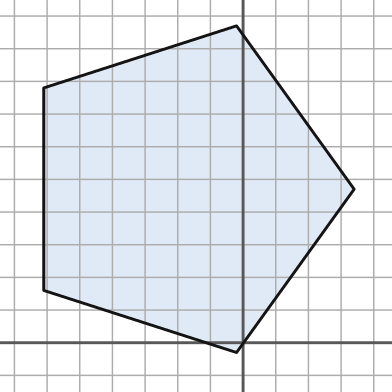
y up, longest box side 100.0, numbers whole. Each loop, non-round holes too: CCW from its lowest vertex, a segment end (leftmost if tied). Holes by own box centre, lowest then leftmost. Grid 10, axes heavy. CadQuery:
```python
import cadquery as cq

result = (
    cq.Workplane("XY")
    .moveTo(-2.0, -3.0)
    .lineTo(34.0, 47.0)
    .lineTo(-2.0, 97.0)
    .lineTo(-61.0, 78.0)
    .lineTo(-61.0, 16.0)
    .close()
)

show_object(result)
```